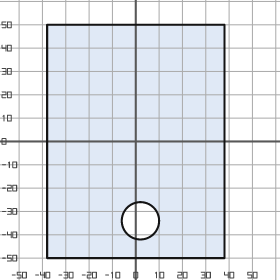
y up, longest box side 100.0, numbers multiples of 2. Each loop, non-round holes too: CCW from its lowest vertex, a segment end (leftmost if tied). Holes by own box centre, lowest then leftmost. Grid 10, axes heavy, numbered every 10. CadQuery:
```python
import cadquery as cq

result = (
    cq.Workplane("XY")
    .moveTo(-38.0, -50.0)
    .lineTo(38.0, -50.0)
    .lineTo(38.0, 50.0)
    .lineTo(-38.0, 50.0)
    .close()
    .moveTo(2.0, -34.0)
    .circle(8.0)
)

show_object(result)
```